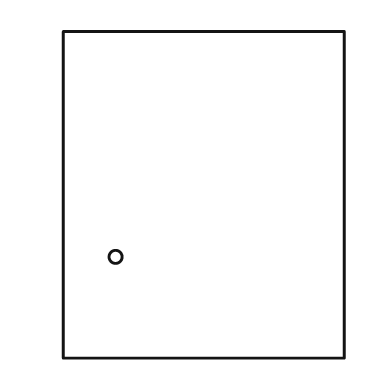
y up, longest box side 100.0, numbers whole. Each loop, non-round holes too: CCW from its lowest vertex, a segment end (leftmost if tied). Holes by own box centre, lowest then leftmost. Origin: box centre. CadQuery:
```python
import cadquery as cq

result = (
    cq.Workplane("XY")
    .moveTo(-43.0, -50.0)
    .lineTo(43.0, -50.0)
    .lineTo(43.0, 50.0)
    .lineTo(-43.0, 50.0)
    .close()
    .moveTo(-27.0, -19.0)
    .circle(2.0)
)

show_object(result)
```